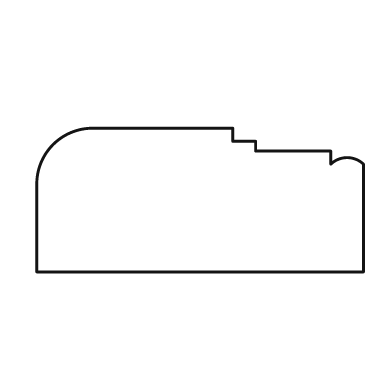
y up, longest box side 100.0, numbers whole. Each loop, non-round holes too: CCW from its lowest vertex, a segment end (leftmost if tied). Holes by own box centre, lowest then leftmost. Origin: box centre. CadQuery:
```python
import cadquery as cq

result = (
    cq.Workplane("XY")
    .moveTo(-50.0, -22.0)
    .lineTo(50.0, -22.0)
    .lineTo(50.0, 11.0)
    .threePointArc((45.0, 13.0), (40.0, 11.0))
    .lineTo(40.0, 15.0)
    .lineTo(17.0, 15.0)
    .lineTo(17.0, 18.0)
    .lineTo(10.0, 18.0)
    .lineTo(10.0, 22.0)
    .lineTo(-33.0, 22.0)
    .threePointArc((-45.0, 17.0), (-50.0, 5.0))
    .close()
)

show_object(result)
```